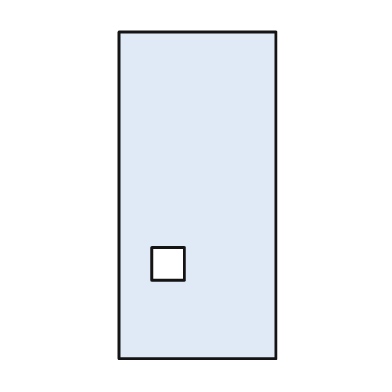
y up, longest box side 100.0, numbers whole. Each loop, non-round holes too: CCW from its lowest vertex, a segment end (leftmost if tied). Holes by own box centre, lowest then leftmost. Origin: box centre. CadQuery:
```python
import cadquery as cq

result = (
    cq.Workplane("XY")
    .moveTo(-24.0, -50.0)
    .lineTo(24.0, -50.0)
    .lineTo(24.0, 50.0)
    .lineTo(-24.0, 50.0)
    .close()
    .moveTo(-14.0, -26.0)
    .lineTo(-4.0, -26.0)
    .lineTo(-4.0, -16.0)
    .lineTo(-14.0, -16.0)
    .close()
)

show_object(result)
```